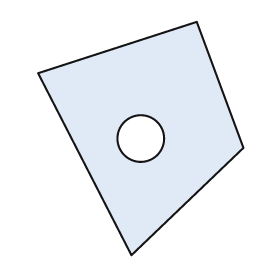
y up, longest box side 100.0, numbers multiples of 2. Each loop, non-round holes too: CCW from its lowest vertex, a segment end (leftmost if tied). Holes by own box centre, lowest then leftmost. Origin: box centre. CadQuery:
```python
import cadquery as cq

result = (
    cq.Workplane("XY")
    .moveTo(-4.0, -50.0)
    .lineTo(44.0, -4.0)
    .lineTo(24.0, 50.0)
    .lineTo(-44.0, 28.0)
    .close()
    .moveTo(0.0, 0.0)
    .circle(10.0)
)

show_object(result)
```